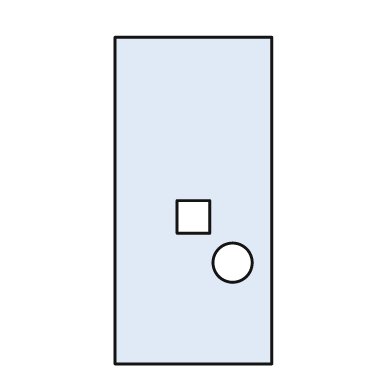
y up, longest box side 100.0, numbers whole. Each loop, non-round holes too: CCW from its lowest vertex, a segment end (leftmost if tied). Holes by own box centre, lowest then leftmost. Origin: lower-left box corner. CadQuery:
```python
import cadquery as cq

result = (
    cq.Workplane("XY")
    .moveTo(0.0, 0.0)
    .lineTo(48.0, 0.0)
    .lineTo(48.0, 100.0)
    .lineTo(0.0, 100.0)
    .close()
    .moveTo(36.0, 31.0)
    .circle(6.0)
    .moveTo(19.0, 40.0)
    .lineTo(29.0, 40.0)
    .lineTo(29.0, 50.0)
    .lineTo(19.0, 50.0)
    .close()
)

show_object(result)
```